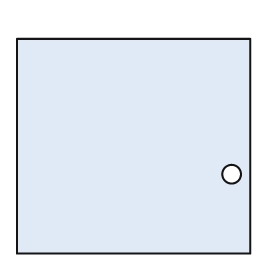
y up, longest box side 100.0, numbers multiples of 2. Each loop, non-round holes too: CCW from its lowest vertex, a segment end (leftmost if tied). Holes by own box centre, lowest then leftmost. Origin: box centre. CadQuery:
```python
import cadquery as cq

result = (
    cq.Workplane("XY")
    .moveTo(-50.0, -46.0)
    .lineTo(50.0, -46.0)
    .lineTo(50.0, 46.0)
    .lineTo(-50.0, 46.0)
    .close()
    .moveTo(42.0, -12.0)
    .circle(4.0)
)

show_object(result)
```